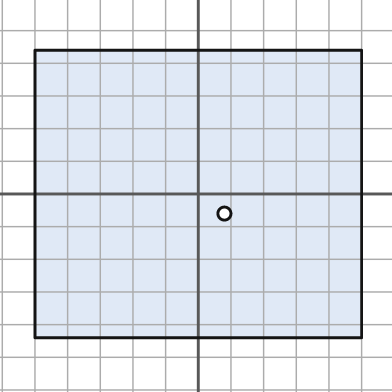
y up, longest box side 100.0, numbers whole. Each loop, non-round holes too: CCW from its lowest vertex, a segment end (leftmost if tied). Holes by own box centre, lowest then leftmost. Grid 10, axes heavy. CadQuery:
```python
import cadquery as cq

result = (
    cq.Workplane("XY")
    .moveTo(-50.0, -44.0)
    .lineTo(50.0, -44.0)
    .lineTo(50.0, 44.0)
    .lineTo(-50.0, 44.0)
    .close()
    .moveTo(8.0, -6.0)
    .circle(2.0)
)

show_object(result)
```